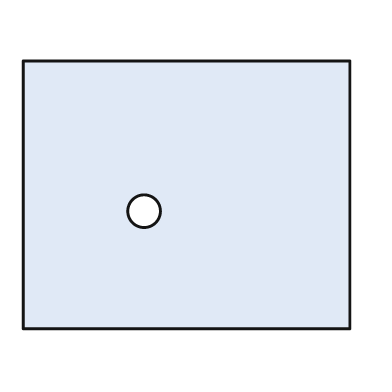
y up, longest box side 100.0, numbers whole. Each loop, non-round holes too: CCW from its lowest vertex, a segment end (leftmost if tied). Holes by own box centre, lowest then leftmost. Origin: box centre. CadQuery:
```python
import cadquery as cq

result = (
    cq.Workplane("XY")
    .moveTo(-50.0, -41.0)
    .lineTo(50.0, -41.0)
    .lineTo(50.0, 41.0)
    .lineTo(-50.0, 41.0)
    .close()
    .moveTo(-13.0, -5.0)
    .circle(5.0)
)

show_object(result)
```